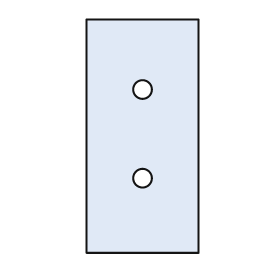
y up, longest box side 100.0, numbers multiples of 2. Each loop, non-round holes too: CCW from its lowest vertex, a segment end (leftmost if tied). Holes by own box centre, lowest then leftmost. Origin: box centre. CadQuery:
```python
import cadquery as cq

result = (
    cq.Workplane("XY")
    .moveTo(-24.0, -50.0)
    .lineTo(24.0, -50.0)
    .lineTo(24.0, 50.0)
    .lineTo(-24.0, 50.0)
    .close()
    .moveTo(0.0, -18.0)
    .circle(4.0)
    .moveTo(0.0, 20.0)
    .circle(4.0)
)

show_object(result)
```